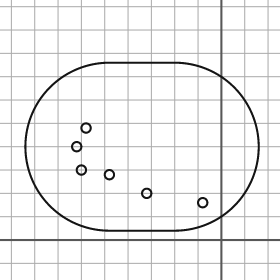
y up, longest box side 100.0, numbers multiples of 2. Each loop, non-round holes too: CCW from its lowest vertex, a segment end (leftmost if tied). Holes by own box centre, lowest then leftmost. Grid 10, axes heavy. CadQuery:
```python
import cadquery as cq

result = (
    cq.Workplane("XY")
    .moveTo(-48.0, 4.0)
    .lineTo(-20.0, 4.0)
    .threePointArc((16.0, 40.0), (-20.0, 76.0))
    .lineTo(-48.0, 76.0)
    .threePointArc((-84.0, 40.0), (-48.0, 4.0))
    .close()
    .moveTo(-8.0, 16.0)
    .circle(2.0)
    .moveTo(-32.0, 20.0)
    .circle(2.0)
    .moveTo(-48.0, 28.0)
    .circle(2.0)
    .moveTo(-60.0, 30.0)
    .circle(2.0)
    .moveTo(-62.0, 40.0)
    .circle(2.0)
    .moveTo(-58.0, 48.0)
    .circle(2.0)
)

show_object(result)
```